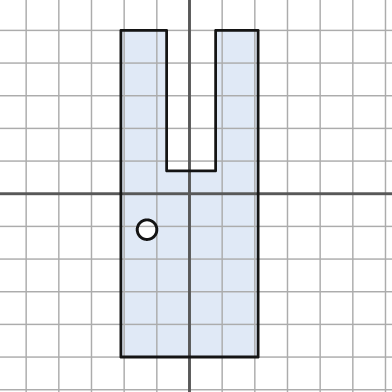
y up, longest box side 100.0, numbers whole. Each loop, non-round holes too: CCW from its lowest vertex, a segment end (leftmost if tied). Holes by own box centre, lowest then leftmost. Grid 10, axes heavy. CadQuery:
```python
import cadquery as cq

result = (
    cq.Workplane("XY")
    .moveTo(-21.0, -50.0)
    .lineTo(21.0, -50.0)
    .lineTo(21.0, 50.0)
    .lineTo(8.0, 50.0)
    .lineTo(8.0, 7.0)
    .lineTo(-7.0, 7.0)
    .lineTo(-7.0, 50.0)
    .lineTo(-21.0, 50.0)
    .close()
    .moveTo(-13.0, -11.0)
    .circle(3.0)
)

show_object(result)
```